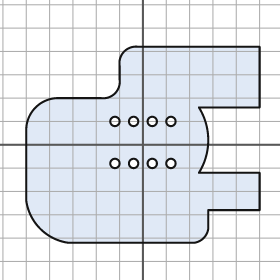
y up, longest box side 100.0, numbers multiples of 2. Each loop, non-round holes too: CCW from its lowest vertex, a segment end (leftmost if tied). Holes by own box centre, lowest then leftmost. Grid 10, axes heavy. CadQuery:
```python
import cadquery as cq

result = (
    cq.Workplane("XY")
    .moveTo(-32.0, -42.0)
    .lineTo(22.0, -42.0)
    .threePointArc((26.0, -40.0), (28.0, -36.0))
    .lineTo(28.0, -28.0)
    .lineTo(50.0, -28.0)
    .lineTo(50.0, -12.0)
    .lineTo(24.0, -12.0)
    .threePointArc((28.0, 2.0), (24.0, 16.0))
    .lineTo(50.0, 16.0)
    .lineTo(50.0, 42.0)
    .lineTo(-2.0, 42.0)
    .threePointArc((-8.0, 40.0), (-10.0, 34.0))
    .lineTo(-10.0, 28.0)
    .threePointArc((-12.0, 22.0), (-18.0, 20.0))
    .lineTo(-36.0, 20.0)
    .threePointArc((-46.0, 16.0), (-50.0, 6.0))
    .lineTo(-50.0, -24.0)
    .threePointArc((-44.0, -36.0), (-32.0, -42.0))
    .close()
    .moveTo(-12.0, -8.0)
    .circle(2.0)
    .moveTo(-4.0, -8.0)
    .circle(2.0)
    .moveTo(4.0, -8.0)
    .circle(2.0)
    .moveTo(12.0, -8.0)
    .circle(2.0)
    .moveTo(-12.0, 10.0)
    .circle(2.0)
    .moveTo(-4.0, 10.0)
    .circle(2.0)
    .moveTo(4.0, 10.0)
    .circle(2.0)
    .moveTo(12.0, 10.0)
    .circle(2.0)
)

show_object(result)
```